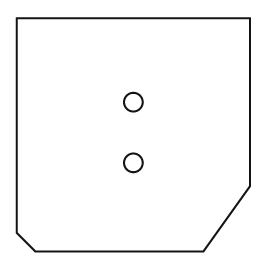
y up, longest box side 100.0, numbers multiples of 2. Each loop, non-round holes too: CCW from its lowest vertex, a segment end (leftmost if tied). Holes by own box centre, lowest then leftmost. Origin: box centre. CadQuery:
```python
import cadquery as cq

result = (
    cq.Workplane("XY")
    .moveTo(-42.0, -50.0)
    .lineTo(30.0, -50.0)
    .lineTo(50.0, -22.0)
    .lineTo(50.0, 50.0)
    .lineTo(-50.0, 50.0)
    .lineTo(-50.0, -42.0)
    .close()
    .moveTo(0.0, -12.0)
    .circle(4.0)
    .moveTo(0.0, 14.0)
    .circle(4.0)
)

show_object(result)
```